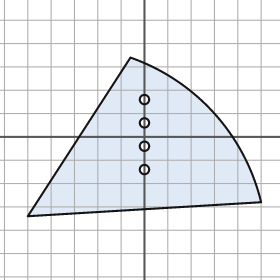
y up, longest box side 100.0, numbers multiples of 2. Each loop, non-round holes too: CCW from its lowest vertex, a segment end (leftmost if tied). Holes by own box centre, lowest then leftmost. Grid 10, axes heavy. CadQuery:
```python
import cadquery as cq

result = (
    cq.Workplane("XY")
    .moveTo(-50.0, -34.0)
    .lineTo(50.0, -28.0)
    .threePointArc((30.0, 10.0), (-6.0, 34.0))
    .close()
    .moveTo(0.0, -14.0)
    .circle(2.0)
    .moveTo(0.0, -4.0)
    .circle(2.0)
    .moveTo(0.0, 6.0)
    .circle(2.0)
    .moveTo(0.0, 16.0)
    .circle(2.0)
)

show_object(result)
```